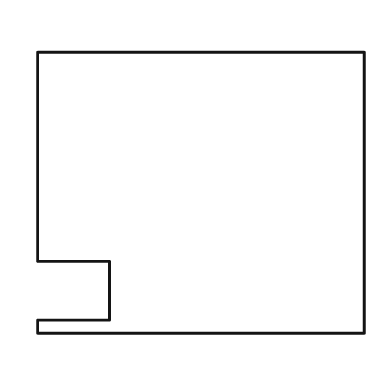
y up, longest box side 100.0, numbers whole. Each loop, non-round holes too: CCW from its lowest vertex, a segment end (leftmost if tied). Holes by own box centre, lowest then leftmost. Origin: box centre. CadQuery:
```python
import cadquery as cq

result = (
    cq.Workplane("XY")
    .moveTo(-50.0, -43.0)
    .lineTo(50.0, -43.0)
    .lineTo(50.0, 43.0)
    .lineTo(-50.0, 43.0)
    .lineTo(-50.0, -21.0)
    .lineTo(-28.0, -21.0)
    .lineTo(-28.0, -39.0)
    .lineTo(-50.0, -39.0)
    .close()
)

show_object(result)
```